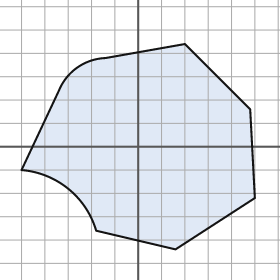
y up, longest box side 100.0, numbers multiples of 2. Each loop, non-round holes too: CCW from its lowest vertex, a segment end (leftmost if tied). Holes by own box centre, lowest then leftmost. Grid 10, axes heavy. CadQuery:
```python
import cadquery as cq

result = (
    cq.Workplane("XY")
    .moveTo(16.0, -44.0)
    .lineTo(50.0, -22.0)
    .lineTo(48.0, 16.0)
    .lineTo(20.0, 44.0)
    .lineTo(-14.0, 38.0)
    .threePointArc((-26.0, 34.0), (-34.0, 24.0))
    .lineTo(-50.0, -10.0)
    .threePointArc((-30.0, -18.0), (-18.0, -36.0))
    .close()
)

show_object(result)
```